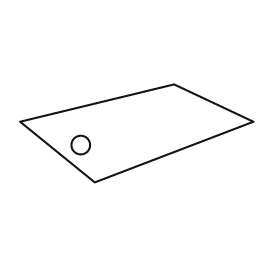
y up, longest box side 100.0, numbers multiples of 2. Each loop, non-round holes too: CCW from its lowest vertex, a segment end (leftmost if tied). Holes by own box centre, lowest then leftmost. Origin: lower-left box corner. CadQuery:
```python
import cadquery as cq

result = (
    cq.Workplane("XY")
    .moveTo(32.0, 0.0)
    .lineTo(100.0, 26.0)
    .lineTo(66.0, 42.0)
    .lineTo(0.0, 26.0)
    .close()
    .moveTo(26.0, 16.0)
    .circle(4.0)
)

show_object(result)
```